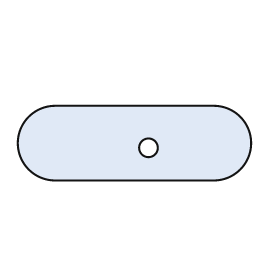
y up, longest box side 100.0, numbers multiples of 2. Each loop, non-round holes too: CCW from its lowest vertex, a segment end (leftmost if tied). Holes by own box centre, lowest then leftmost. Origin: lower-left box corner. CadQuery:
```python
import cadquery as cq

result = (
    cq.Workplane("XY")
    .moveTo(16.0, 0.0)
    .lineTo(84.0, 0.0)
    .threePointArc((100.0, 16.0), (84.0, 32.0))
    .lineTo(16.0, 32.0)
    .threePointArc((0.0, 16.0), (16.0, 0.0))
    .close()
    .moveTo(56.0, 14.0)
    .circle(4.0)
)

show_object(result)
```